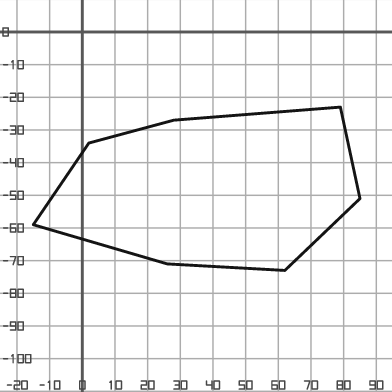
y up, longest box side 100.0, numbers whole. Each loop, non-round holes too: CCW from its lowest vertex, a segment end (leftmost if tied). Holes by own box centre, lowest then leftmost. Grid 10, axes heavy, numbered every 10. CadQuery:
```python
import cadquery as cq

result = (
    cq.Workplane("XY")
    .moveTo(62.0, -73.0)
    .lineTo(85.0, -51.0)
    .lineTo(79.0, -23.0)
    .lineTo(28.0, -27.0)
    .lineTo(2.0, -34.0)
    .lineTo(-15.0, -59.0)
    .lineTo(26.0, -71.0)
    .close()
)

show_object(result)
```